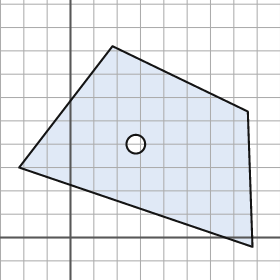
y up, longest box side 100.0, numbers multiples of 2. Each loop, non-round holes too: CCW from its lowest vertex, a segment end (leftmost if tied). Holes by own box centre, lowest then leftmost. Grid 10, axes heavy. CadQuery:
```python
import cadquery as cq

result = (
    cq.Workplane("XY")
    .moveTo(78.0, -4.0)
    .lineTo(76.0, 54.0)
    .lineTo(18.0, 82.0)
    .lineTo(-22.0, 30.0)
    .close()
    .moveTo(28.0, 40.0)
    .circle(4.0)
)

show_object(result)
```